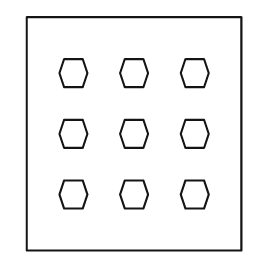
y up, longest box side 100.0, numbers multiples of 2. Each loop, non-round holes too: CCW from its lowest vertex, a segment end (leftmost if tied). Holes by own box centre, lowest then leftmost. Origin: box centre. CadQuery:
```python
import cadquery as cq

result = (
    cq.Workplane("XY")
    .moveTo(-46.0, -50.0)
    .lineTo(46.0, -50.0)
    .lineTo(46.0, 50.0)
    .lineTo(-46.0, 50.0)
    .close()
    .moveTo(-30.0, -32.0)
    .lineTo(-22.0, -32.0)
    .lineTo(-20.0, -26.0)
    .lineTo(-22.0, -20.0)
    .lineTo(-30.0, -20.0)
    .lineTo(-32.0, -26.0)
    .close()
    .moveTo(-4.0, -32.0)
    .lineTo(4.0, -32.0)
    .lineTo(6.0, -26.0)
    .lineTo(4.0, -20.0)
    .lineTo(-4.0, -20.0)
    .lineTo(-6.0, -26.0)
    .close()
    .moveTo(22.0, -32.0)
    .lineTo(30.0, -32.0)
    .lineTo(32.0, -26.0)
    .lineTo(30.0, -20.0)
    .lineTo(22.0, -20.0)
    .lineTo(20.0, -26.0)
    .close()
    .moveTo(-30.0, -6.0)
    .lineTo(-22.0, -6.0)
    .lineTo(-20.0, 0.0)
    .lineTo(-22.0, 6.0)
    .lineTo(-30.0, 6.0)
    .lineTo(-32.0, 0.0)
    .close()
    .moveTo(-4.0, -6.0)
    .lineTo(4.0, -6.0)
    .lineTo(6.0, 0.0)
    .lineTo(4.0, 6.0)
    .lineTo(-4.0, 6.0)
    .lineTo(-6.0, 0.0)
    .close()
    .moveTo(22.0, -6.0)
    .lineTo(30.0, -6.0)
    .lineTo(32.0, 0.0)
    .lineTo(30.0, 6.0)
    .lineTo(22.0, 6.0)
    .lineTo(20.0, 0.0)
    .close()
    .moveTo(-30.0, 20.0)
    .lineTo(-22.0, 20.0)
    .lineTo(-20.0, 26.0)
    .lineTo(-22.0, 32.0)
    .lineTo(-30.0, 32.0)
    .lineTo(-32.0, 26.0)
    .close()
    .moveTo(-4.0, 20.0)
    .lineTo(4.0, 20.0)
    .lineTo(6.0, 26.0)
    .lineTo(4.0, 32.0)
    .lineTo(-4.0, 32.0)
    .lineTo(-6.0, 26.0)
    .close()
    .moveTo(22.0, 20.0)
    .lineTo(30.0, 20.0)
    .lineTo(32.0, 26.0)
    .lineTo(30.0, 32.0)
    .lineTo(22.0, 32.0)
    .lineTo(20.0, 26.0)
    .close()
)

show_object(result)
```